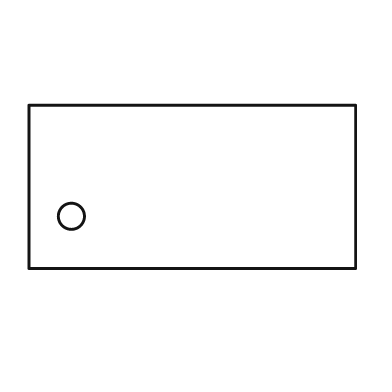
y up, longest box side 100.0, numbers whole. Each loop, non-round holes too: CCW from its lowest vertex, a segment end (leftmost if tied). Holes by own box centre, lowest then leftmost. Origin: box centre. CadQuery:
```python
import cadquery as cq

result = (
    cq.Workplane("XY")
    .moveTo(-50.0, -25.0)
    .lineTo(50.0, -25.0)
    .lineTo(50.0, 25.0)
    .lineTo(-50.0, 25.0)
    .close()
    .moveTo(-37.0, -9.0)
    .circle(4.0)
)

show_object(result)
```